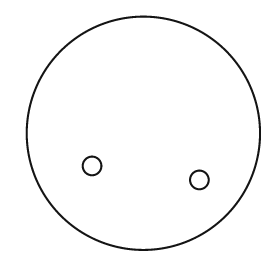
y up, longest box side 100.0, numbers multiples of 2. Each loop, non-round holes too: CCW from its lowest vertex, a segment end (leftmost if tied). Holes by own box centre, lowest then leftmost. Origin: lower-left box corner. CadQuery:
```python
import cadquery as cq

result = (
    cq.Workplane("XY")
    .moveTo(50.0, 50.0)
    .circle(50.0)
    .moveTo(74.0, 30.0)
    .circle(4.0)
    .moveTo(28.0, 36.0)
    .circle(4.0)
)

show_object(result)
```